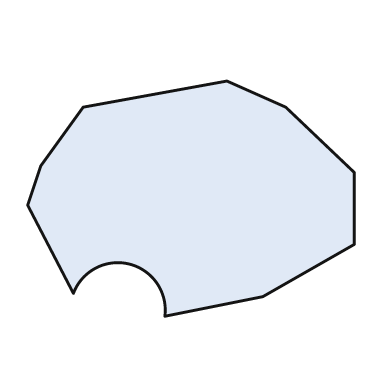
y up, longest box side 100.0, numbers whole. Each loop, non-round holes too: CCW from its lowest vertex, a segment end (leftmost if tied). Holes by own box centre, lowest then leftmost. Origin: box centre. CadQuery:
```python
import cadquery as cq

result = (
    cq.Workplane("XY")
    .moveTo(-8.0, -36.0)
    .lineTo(22.0, -30.0)
    .lineTo(50.0, -14.0)
    .lineTo(50.0, 8.0)
    .lineTo(29.0, 28.0)
    .lineTo(11.0, 36.0)
    .lineTo(-33.0, 28.0)
    .lineTo(-46.0, 10.0)
    .lineTo(-50.0, -2.0)
    .lineTo(-36.0, -29.0)
    .threePointArc((-19.0, -20.0), (-8.0, -36.0))
    .close()
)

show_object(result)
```